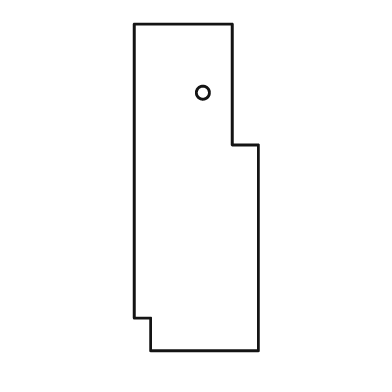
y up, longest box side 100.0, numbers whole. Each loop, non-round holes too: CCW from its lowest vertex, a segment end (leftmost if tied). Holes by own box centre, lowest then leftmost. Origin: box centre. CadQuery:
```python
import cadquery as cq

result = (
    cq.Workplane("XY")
    .moveTo(-14.0, -50.0)
    .lineTo(19.0, -50.0)
    .lineTo(19.0, 13.0)
    .lineTo(11.0, 13.0)
    .lineTo(11.0, 50.0)
    .lineTo(-19.0, 50.0)
    .lineTo(-19.0, -40.0)
    .lineTo(-14.0, -40.0)
    .close()
    .moveTo(2.0, 29.0)
    .circle(2.0)
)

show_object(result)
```